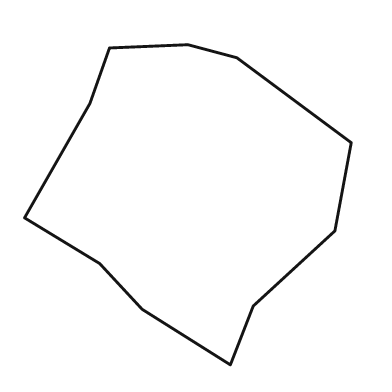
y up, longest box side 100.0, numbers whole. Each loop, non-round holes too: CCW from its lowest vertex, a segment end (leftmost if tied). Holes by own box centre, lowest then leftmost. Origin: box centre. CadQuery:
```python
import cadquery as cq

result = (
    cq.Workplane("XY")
    .moveTo(13.0, -49.0)
    .lineTo(20.0, -31.0)
    .lineTo(45.0, -8.0)
    .lineTo(50.0, 19.0)
    .lineTo(15.0, 45.0)
    .lineTo(0.0, 49.0)
    .lineTo(-24.0, 48.0)
    .lineTo(-30.0, 31.0)
    .lineTo(-50.0, -4.0)
    .lineTo(-27.0, -18.0)
    .lineTo(-14.0, -32.0)
    .close()
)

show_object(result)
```